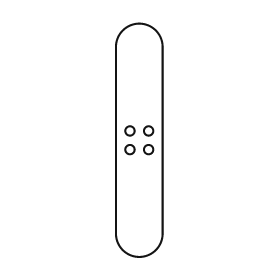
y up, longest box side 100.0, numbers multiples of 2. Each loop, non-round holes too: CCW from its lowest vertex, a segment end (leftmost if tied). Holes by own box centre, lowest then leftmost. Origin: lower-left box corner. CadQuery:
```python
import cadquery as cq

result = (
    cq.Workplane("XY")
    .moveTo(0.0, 10.0)
    .threePointArc((10.0, 0.0), (20.0, 10.0))
    .lineTo(20.0, 90.0)
    .threePointArc((10.0, 100.0), (0.0, 90.0))
    .close()
    .moveTo(6.0, 46.0)
    .circle(2.0)
    .moveTo(14.0, 46.0)
    .circle(2.0)
    .moveTo(6.0, 54.0)
    .circle(2.0)
    .moveTo(14.0, 54.0)
    .circle(2.0)
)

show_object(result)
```